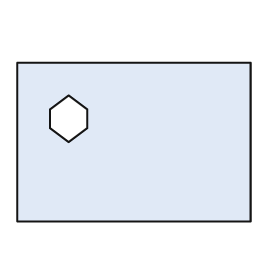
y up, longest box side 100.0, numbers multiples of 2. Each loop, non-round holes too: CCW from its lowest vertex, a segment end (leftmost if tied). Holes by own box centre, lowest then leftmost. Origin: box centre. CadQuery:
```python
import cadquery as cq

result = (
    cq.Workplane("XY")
    .moveTo(-50.0, -34.0)
    .lineTo(50.0, -34.0)
    .lineTo(50.0, 34.0)
    .lineTo(-50.0, 34.0)
    .close()
    .moveTo(-28.0, 0.0)
    .lineTo(-20.0, 6.0)
    .lineTo(-20.0, 14.0)
    .lineTo(-28.0, 20.0)
    .lineTo(-36.0, 14.0)
    .lineTo(-36.0, 6.0)
    .close()
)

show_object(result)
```